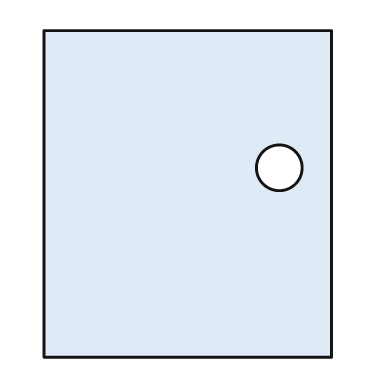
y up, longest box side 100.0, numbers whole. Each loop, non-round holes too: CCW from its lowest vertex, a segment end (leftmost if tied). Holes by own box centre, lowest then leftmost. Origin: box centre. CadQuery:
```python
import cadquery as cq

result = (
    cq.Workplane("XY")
    .moveTo(-44.0, -50.0)
    .lineTo(44.0, -50.0)
    .lineTo(44.0, 50.0)
    .lineTo(-44.0, 50.0)
    .close()
    .moveTo(28.0, 8.0)
    .circle(7.0)
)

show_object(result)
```